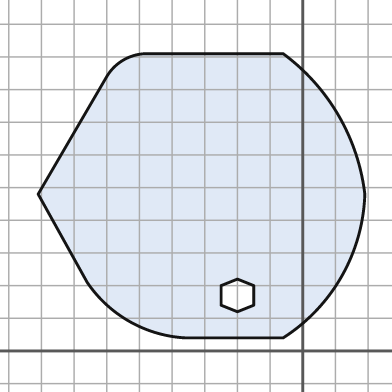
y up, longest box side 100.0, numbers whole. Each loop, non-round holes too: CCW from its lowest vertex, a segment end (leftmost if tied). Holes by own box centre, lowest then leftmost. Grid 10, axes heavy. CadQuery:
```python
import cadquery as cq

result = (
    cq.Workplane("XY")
    .moveTo(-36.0, 4.0)
    .lineTo(-6.0, 4.0)
    .threePointArc((12.0, 23.0), (19.0, 48.0))
    .threePointArc((11.0, 72.0), (-6.0, 91.0))
    .lineTo(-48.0, 91.0)
    .threePointArc((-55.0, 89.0), (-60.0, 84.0))
    .lineTo(-81.0, 48.0)
    .lineTo(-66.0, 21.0)
    .threePointArc((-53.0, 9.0), (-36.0, 4.0))
    .close()
    .moveTo(-20.0, 12.0)
    .lineTo(-15.0, 14.0)
    .lineTo(-15.0, 20.0)
    .lineTo(-20.0, 22.0)
    .lineTo(-25.0, 20.0)
    .lineTo(-25.0, 14.0)
    .close()
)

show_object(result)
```